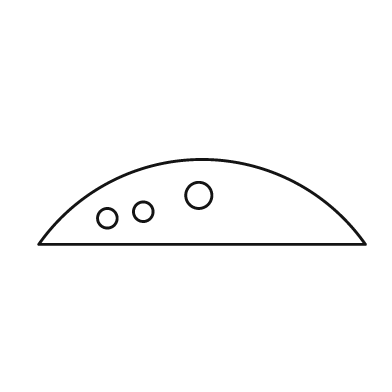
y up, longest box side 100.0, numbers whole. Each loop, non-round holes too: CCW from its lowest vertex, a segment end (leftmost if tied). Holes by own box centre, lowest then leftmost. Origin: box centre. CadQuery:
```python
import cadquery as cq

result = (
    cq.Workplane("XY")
    .moveTo(-50.0, -13.0)
    .lineTo(50.0, -13.0)
    .threePointArc((0.0, 13.0), (-50.0, -13.0))
    .close()
    .moveTo(-29.0, -5.0)
    .circle(3.0)
    .moveTo(-18.0, -3.0)
    .circle(3.0)
    .moveTo(-1.0, 2.0)
    .circle(4.0)
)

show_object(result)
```